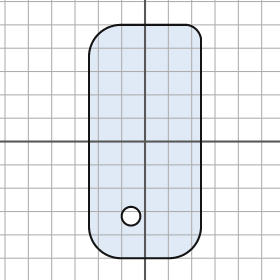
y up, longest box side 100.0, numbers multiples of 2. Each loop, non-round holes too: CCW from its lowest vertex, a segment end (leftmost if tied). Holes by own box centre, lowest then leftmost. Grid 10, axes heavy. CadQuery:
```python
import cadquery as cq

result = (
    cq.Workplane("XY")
    .moveTo(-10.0, -50.0)
    .lineTo(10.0, -50.0)
    .threePointArc((20.0, -46.0), (24.0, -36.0))
    .lineTo(24.0, 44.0)
    .threePointArc((22.0, 48.0), (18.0, 50.0))
    .lineTo(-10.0, 50.0)
    .threePointArc((-20.0, 46.0), (-24.0, 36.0))
    .lineTo(-24.0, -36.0)
    .threePointArc((-20.0, -46.0), (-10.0, -50.0))
    .close()
    .moveTo(-6.0, -32.0)
    .circle(4.0)
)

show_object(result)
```